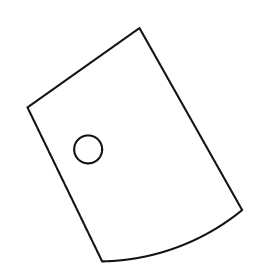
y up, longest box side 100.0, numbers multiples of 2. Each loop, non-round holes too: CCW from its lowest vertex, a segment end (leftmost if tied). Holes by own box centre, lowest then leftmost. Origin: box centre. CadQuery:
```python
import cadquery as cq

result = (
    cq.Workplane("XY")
    .moveTo(-14.0, -50.0)
    .threePointArc((18.0, -44.0), (46.0, -28.0))
    .lineTo(2.0, 50.0)
    .lineTo(-46.0, 16.0)
    .close()
    .moveTo(-20.0, -2.0)
    .circle(6.0)
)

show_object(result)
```